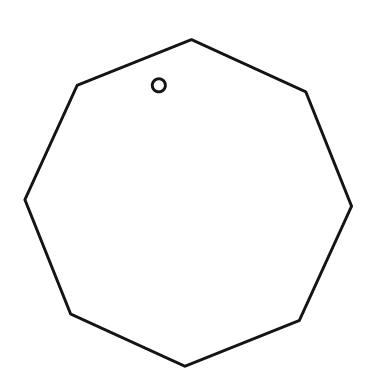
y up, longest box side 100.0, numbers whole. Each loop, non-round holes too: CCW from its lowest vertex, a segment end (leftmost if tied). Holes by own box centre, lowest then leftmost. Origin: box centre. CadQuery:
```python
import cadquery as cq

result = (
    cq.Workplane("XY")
    .moveTo(-1.0, -50.0)
    .lineTo(34.0, -36.0)
    .lineTo(50.0, -1.0)
    .lineTo(36.0, 34.0)
    .lineTo(1.0, 50.0)
    .lineTo(-34.0, 36.0)
    .lineTo(-50.0, 1.0)
    .lineTo(-36.0, -34.0)
    .close()
    .moveTo(-9.0, 36.0)
    .circle(2.0)
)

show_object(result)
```